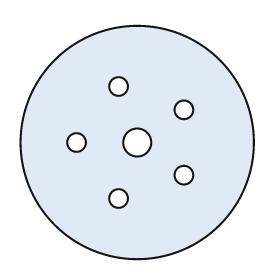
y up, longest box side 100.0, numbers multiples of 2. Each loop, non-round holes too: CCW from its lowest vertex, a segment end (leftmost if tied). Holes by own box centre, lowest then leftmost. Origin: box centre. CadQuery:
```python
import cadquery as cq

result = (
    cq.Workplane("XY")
    .moveTo(0.0, 0.0)
    .circle(50.0)
    .moveTo(-8.0, -24.0)
    .circle(4.0)
    .moveTo(20.0, -14.0)
    .circle(4.0)
    .moveTo(-26.0, 0.0)
    .circle(4.0)
    .moveTo(0.0, 0.0)
    .circle(6.0)
    .moveTo(20.0, 14.0)
    .circle(4.0)
    .moveTo(-8.0, 24.0)
    .circle(4.0)
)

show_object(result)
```